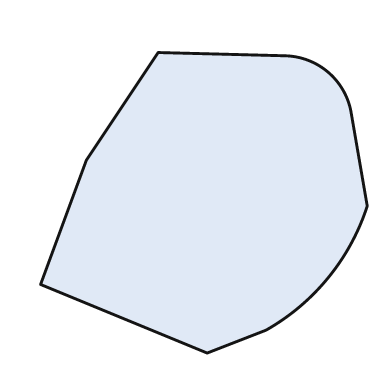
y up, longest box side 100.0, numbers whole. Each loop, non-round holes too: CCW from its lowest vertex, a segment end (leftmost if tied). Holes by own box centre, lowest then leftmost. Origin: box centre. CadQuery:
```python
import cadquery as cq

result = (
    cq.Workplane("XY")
    .moveTo(1.0, -46.0)
    .lineTo(19.0, -39.0)
    .threePointArc((38.0, -23.0), (50.0, -1.0))
    .lineTo(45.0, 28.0)
    .threePointArc((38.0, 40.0), (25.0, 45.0))
    .lineTo(-14.0, 46.0)
    .lineTo(-36.0, 13.0)
    .lineTo(-50.0, -25.0)
    .close()
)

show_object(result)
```